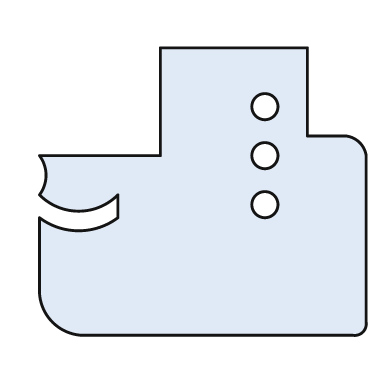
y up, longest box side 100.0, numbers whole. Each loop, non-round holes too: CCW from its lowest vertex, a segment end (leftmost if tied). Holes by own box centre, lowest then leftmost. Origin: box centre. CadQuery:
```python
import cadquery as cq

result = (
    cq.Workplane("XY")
    .moveTo(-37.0, -44.0)
    .lineTo(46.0, -44.0)
    .threePointArc((49.0, -43.0), (50.0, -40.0))
    .lineTo(50.0, 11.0)
    .threePointArc((48.0, 15.0), (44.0, 17.0))
    .lineTo(32.0, 17.0)
    .lineTo(32.0, 44.0)
    .lineTo(-13.0, 44.0)
    .lineTo(-13.0, 11.0)
    .lineTo(-50.0, 11.0)
    .threePointArc((-48.0, 5.0), (-50.0, -1.0))
    .threePointArc((-38.0, -6.0), (-26.0, -1.0))
    .lineTo(-26.0, -8.0)
    .threePointArc((-38.0, -12.0), (-50.0, -8.0))
    .lineTo(-50.0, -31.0)
    .threePointArc((-46.0, -40.0), (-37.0, -44.0))
    .close()
    .moveTo(19.0, -4.0)
    .circle(4.0)
    .moveTo(19.0, 11.0)
    .circle(4.0)
    .moveTo(19.0, 26.0)
    .circle(4.0)
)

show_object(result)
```